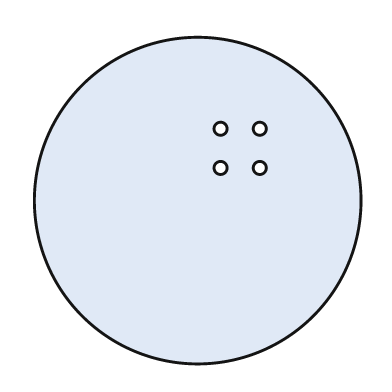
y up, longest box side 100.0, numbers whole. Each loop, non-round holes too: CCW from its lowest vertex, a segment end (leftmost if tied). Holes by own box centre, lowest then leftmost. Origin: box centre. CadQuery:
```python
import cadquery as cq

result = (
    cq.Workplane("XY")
    .moveTo(0.0, 0.0)
    .circle(50.0)
    .moveTo(7.0, 10.0)
    .circle(2.0)
    .moveTo(19.0, 10.0)
    .circle(2.0)
    .moveTo(7.0, 22.0)
    .circle(2.0)
    .moveTo(19.0, 22.0)
    .circle(2.0)
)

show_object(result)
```